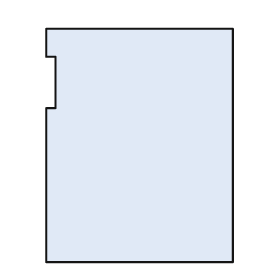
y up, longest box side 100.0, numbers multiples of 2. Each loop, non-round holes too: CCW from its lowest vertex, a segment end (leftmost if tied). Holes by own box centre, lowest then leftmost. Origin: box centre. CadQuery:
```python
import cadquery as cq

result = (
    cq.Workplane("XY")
    .moveTo(-40.0, -50.0)
    .lineTo(40.0, -50.0)
    .lineTo(40.0, 50.0)
    .lineTo(-40.0, 50.0)
    .lineTo(-40.0, 38.0)
    .lineTo(-36.0, 38.0)
    .lineTo(-36.0, 16.0)
    .lineTo(-40.0, 16.0)
    .close()
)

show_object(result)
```